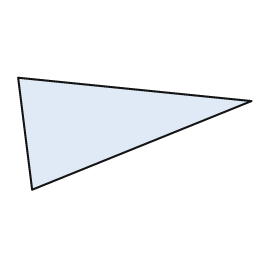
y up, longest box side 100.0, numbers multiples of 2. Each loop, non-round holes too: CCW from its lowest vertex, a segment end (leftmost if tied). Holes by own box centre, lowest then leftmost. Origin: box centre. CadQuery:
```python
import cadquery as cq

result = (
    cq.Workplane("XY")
    .moveTo(-44.0, -24.0)
    .lineTo(50.0, 14.0)
    .lineTo(-50.0, 24.0)
    .close()
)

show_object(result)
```